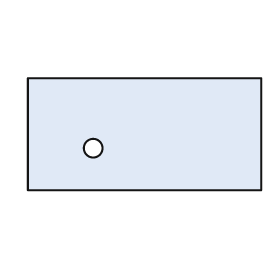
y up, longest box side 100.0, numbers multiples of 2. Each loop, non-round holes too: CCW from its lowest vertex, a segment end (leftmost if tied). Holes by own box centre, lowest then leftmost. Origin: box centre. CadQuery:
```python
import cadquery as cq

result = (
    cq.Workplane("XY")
    .moveTo(-50.0, -24.0)
    .lineTo(50.0, -24.0)
    .lineTo(50.0, 24.0)
    .lineTo(-50.0, 24.0)
    .close()
    .moveTo(-22.0, -6.0)
    .circle(4.0)
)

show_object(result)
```